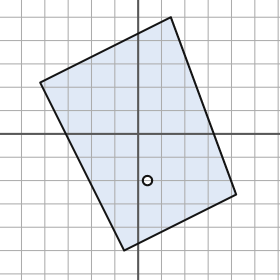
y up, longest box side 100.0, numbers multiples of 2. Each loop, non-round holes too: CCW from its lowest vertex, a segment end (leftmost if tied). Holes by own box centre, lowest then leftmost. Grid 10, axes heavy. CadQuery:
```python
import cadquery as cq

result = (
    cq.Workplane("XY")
    .moveTo(-6.0, -50.0)
    .lineTo(42.0, -26.0)
    .lineTo(14.0, 50.0)
    .lineTo(-42.0, 22.0)
    .close()
    .moveTo(4.0, -20.0)
    .circle(2.0)
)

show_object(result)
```